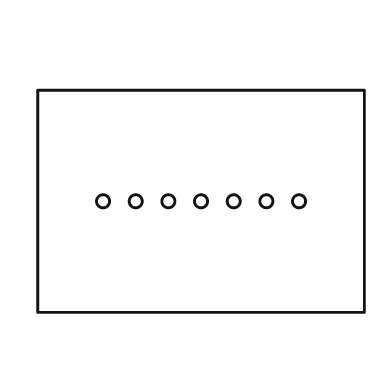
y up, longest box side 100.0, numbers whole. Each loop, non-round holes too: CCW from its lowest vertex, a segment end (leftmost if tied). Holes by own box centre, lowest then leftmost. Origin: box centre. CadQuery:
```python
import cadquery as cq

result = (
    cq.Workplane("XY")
    .moveTo(-50.0, -34.0)
    .lineTo(50.0, -34.0)
    .lineTo(50.0, 34.0)
    .lineTo(-50.0, 34.0)
    .close()
    .moveTo(-30.0, 0.0)
    .circle(2.0)
    .moveTo(-20.0, 0.0)
    .circle(2.0)
    .moveTo(-10.0, 0.0)
    .circle(2.0)
    .moveTo(0.0, 0.0)
    .circle(2.0)
    .moveTo(10.0, 0.0)
    .circle(2.0)
    .moveTo(20.0, 0.0)
    .circle(2.0)
    .moveTo(30.0, 0.0)
    .circle(2.0)
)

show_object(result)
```